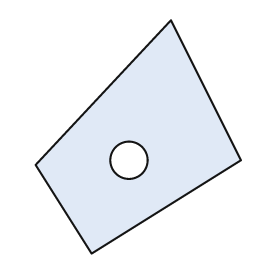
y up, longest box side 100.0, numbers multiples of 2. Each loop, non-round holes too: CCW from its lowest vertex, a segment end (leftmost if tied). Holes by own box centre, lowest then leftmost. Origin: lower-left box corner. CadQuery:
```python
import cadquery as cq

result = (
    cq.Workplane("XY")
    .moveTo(24.0, 0.0)
    .lineTo(88.0, 40.0)
    .lineTo(58.0, 100.0)
    .lineTo(0.0, 38.0)
    .close()
    .moveTo(40.0, 40.0)
    .circle(8.0)
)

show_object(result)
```